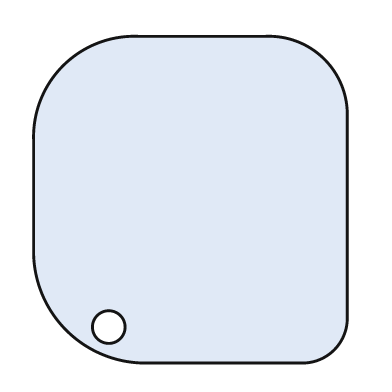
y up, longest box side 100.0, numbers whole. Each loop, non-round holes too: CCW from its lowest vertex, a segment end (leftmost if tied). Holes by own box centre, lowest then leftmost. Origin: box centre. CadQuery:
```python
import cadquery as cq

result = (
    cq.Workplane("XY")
    .moveTo(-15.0, -50.0)
    .lineTo(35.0, -50.0)
    .threePointArc((44.0, -46.0), (48.0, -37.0))
    .lineTo(48.0, 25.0)
    .threePointArc((41.0, 43.0), (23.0, 50.0))
    .lineTo(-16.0, 50.0)
    .threePointArc((-39.0, 41.0), (-48.0, 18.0))
    .lineTo(-48.0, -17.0)
    .threePointArc((-38.0, -40.0), (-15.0, -50.0))
    .close()
    .moveTo(-25.0, -39.0)
    .circle(5.0)
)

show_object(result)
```